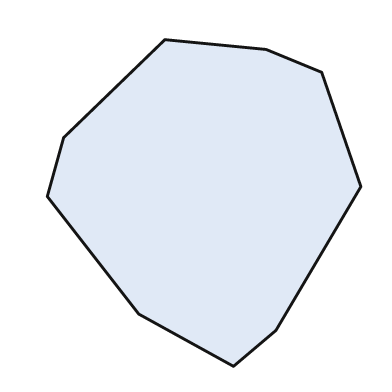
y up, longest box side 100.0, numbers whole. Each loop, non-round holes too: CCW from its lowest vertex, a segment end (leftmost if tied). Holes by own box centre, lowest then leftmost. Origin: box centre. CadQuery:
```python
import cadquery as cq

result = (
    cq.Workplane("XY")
    .moveTo(9.0, -50.0)
    .lineTo(22.0, -39.0)
    .lineTo(48.0, 5.0)
    .lineTo(36.0, 40.0)
    .lineTo(19.0, 47.0)
    .lineTo(-12.0, 50.0)
    .lineTo(-43.0, 20.0)
    .lineTo(-48.0, 2.0)
    .lineTo(-20.0, -34.0)
    .close()
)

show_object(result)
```